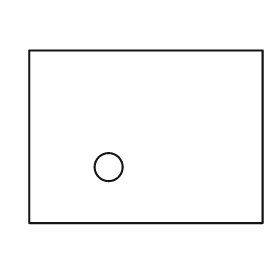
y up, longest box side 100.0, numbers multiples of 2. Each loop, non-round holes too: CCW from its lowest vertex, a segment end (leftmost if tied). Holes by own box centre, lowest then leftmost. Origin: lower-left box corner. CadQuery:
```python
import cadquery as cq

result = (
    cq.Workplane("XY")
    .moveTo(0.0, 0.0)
    .lineTo(100.0, 0.0)
    .lineTo(100.0, 74.0)
    .lineTo(0.0, 74.0)
    .close()
    .moveTo(34.0, 24.0)
    .circle(6.0)
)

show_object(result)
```